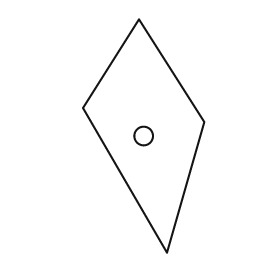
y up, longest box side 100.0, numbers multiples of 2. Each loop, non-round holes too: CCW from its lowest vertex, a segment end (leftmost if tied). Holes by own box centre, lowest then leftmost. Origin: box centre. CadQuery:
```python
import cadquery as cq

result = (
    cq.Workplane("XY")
    .moveTo(10.0, -50.0)
    .lineTo(26.0, 6.0)
    .lineTo(-2.0, 50.0)
    .lineTo(-26.0, 12.0)
    .close()
    .moveTo(0.0, 0.0)
    .circle(4.0)
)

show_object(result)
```